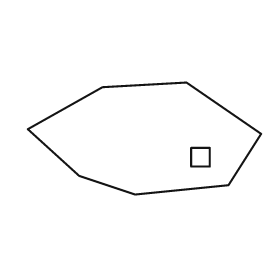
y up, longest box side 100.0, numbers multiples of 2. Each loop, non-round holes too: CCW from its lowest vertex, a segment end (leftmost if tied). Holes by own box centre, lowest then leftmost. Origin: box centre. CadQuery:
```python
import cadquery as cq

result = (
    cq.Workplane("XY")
    .moveTo(-4.0, -24.0)
    .lineTo(36.0, -20.0)
    .lineTo(50.0, 2.0)
    .lineTo(18.0, 24.0)
    .lineTo(-18.0, 22.0)
    .lineTo(-50.0, 4.0)
    .lineTo(-28.0, -16.0)
    .close()
    .moveTo(20.0, -12.0)
    .lineTo(28.0, -12.0)
    .lineTo(28.0, -4.0)
    .lineTo(20.0, -4.0)
    .close()
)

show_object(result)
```